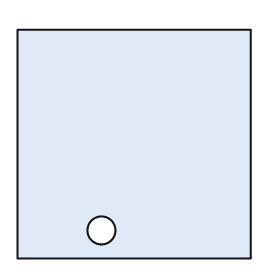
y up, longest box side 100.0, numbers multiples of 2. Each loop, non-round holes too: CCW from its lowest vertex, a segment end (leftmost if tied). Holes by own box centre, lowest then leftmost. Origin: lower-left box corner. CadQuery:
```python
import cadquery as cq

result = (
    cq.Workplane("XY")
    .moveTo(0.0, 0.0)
    .lineTo(100.0, 0.0)
    .lineTo(100.0, 98.0)
    .lineTo(0.0, 98.0)
    .close()
    .moveTo(36.0, 12.0)
    .circle(6.0)
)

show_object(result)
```